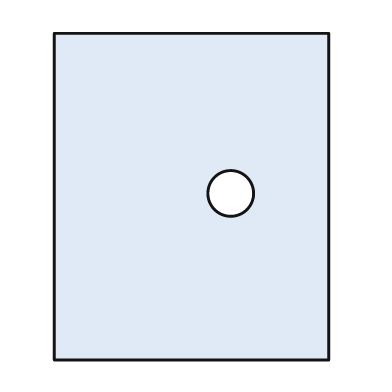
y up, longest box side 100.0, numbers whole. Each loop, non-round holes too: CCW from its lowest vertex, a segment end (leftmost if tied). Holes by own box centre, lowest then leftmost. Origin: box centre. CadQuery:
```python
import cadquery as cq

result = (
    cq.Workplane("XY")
    .moveTo(-42.0, -50.0)
    .lineTo(42.0, -50.0)
    .lineTo(42.0, 50.0)
    .lineTo(-42.0, 50.0)
    .close()
    .moveTo(12.0, 1.0)
    .circle(7.0)
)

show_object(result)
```